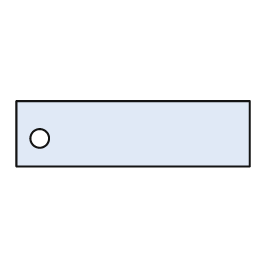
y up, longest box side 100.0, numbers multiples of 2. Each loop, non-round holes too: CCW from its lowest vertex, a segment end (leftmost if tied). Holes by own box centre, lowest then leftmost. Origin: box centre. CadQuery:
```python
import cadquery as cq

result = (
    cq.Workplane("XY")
    .moveTo(-50.0, -14.0)
    .lineTo(50.0, -14.0)
    .lineTo(50.0, 14.0)
    .lineTo(-50.0, 14.0)
    .close()
    .moveTo(-40.0, -2.0)
    .circle(4.0)
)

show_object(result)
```